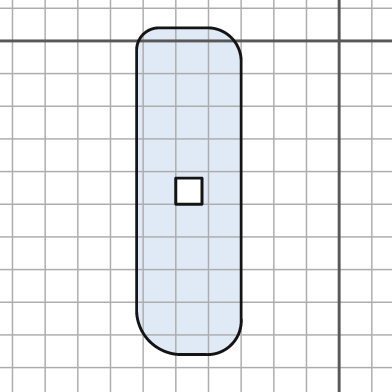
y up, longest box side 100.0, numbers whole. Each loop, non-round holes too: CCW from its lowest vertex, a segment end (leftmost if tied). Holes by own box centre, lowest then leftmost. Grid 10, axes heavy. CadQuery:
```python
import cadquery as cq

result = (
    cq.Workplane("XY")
    .moveTo(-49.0, -96.0)
    .lineTo(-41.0, -96.0)
    .threePointArc((-33.0, -93.0), (-30.0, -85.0))
    .lineTo(-30.0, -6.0)
    .threePointArc((-33.0, 1.0), (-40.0, 4.0))
    .lineTo(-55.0, 4.0)
    .threePointArc((-60.0, 2.0), (-62.0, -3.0))
    .lineTo(-62.0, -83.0)
    .threePointArc((-58.0, -92.0), (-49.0, -96.0))
    .close()
    .moveTo(-50.0, -50.0)
    .lineTo(-42.0, -50.0)
    .lineTo(-42.0, -42.0)
    .lineTo(-50.0, -42.0)
    .close()
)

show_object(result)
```